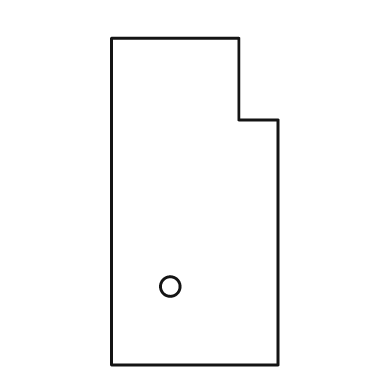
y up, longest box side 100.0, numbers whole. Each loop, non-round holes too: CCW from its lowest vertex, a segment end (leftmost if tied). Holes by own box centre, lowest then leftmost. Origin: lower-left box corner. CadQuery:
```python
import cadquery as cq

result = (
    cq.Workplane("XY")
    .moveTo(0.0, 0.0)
    .lineTo(51.0, 0.0)
    .lineTo(51.0, 75.0)
    .lineTo(39.0, 75.0)
    .lineTo(39.0, 100.0)
    .lineTo(0.0, 100.0)
    .close()
    .moveTo(18.0, 24.0)
    .circle(3.0)
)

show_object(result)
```